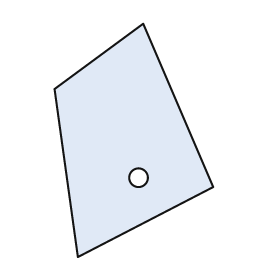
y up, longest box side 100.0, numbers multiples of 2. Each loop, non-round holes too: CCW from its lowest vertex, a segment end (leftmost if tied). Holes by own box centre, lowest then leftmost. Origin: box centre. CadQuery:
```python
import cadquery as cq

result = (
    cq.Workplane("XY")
    .moveTo(-24.0, -50.0)
    .lineTo(34.0, -20.0)
    .lineTo(4.0, 50.0)
    .lineTo(-34.0, 22.0)
    .close()
    .moveTo(2.0, -16.0)
    .circle(4.0)
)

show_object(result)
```